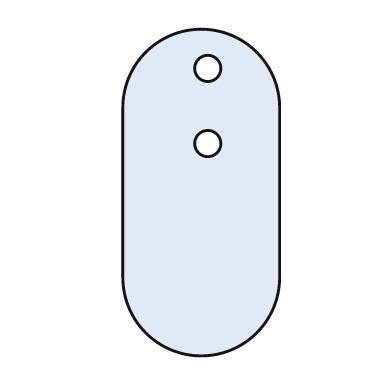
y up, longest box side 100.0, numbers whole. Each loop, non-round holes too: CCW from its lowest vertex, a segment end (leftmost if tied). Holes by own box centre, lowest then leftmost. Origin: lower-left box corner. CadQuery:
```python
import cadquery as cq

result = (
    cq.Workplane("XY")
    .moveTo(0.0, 24.0)
    .threePointArc((24.0, 0.0), (48.0, 24.0))
    .lineTo(48.0, 76.0)
    .threePointArc((24.0, 100.0), (0.0, 76.0))
    .close()
    .moveTo(26.0, 65.0)
    .circle(4.0)
    .moveTo(26.0, 88.0)
    .circle(4.0)
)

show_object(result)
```